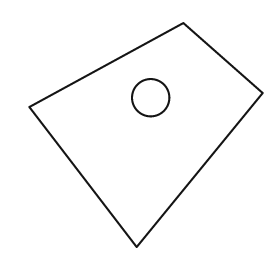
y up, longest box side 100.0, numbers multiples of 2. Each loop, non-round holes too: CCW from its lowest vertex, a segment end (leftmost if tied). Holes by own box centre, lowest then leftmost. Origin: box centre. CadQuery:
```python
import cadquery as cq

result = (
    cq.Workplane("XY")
    .moveTo(-4.0, -48.0)
    .lineTo(50.0, 18.0)
    .lineTo(16.0, 48.0)
    .lineTo(-50.0, 12.0)
    .close()
    .moveTo(2.0, 16.0)
    .circle(8.0)
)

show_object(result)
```